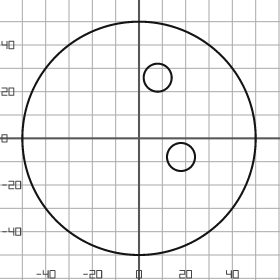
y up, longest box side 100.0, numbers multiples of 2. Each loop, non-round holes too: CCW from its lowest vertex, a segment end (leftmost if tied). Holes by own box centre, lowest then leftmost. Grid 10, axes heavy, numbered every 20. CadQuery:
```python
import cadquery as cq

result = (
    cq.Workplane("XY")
    .moveTo(0.0, 0.0)
    .circle(50.0)
    .moveTo(18.0, -8.0)
    .circle(6.0)
    .moveTo(8.0, 26.0)
    .circle(6.0)
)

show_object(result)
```